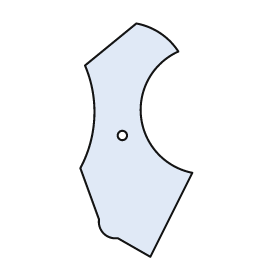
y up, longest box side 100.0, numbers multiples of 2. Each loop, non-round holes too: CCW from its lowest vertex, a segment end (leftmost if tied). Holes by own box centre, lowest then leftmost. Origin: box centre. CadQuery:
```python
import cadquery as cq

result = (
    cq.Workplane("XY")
    .moveTo(6.0, -50.0)
    .lineTo(24.0, -14.0)
    .threePointArc((2.0, 10.0), (18.0, 38.0))
    .threePointArc((10.0, 46.0), (0.0, 50.0))
    .lineTo(-22.0, 32.0)
    .threePointArc((-18.0, 10.0), (-24.0, -12.0))
    .lineTo(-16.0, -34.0)
    .threePointArc((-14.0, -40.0), (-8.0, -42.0))
    .close()
    .moveTo(-6.0, 2.0)
    .circle(2.0)
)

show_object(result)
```